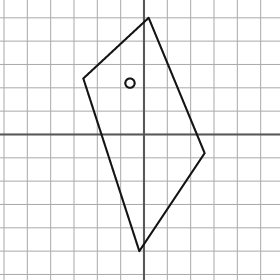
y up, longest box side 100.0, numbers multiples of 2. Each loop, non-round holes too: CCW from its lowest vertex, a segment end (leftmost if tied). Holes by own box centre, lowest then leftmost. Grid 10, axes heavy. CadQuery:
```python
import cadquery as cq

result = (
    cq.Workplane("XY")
    .moveTo(-2.0, -50.0)
    .lineTo(26.0, -8.0)
    .lineTo(2.0, 50.0)
    .lineTo(-26.0, 24.0)
    .close()
    .moveTo(-6.0, 22.0)
    .circle(2.0)
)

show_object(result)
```